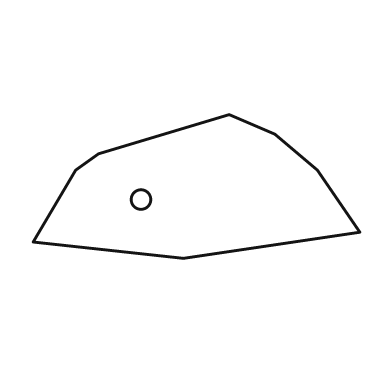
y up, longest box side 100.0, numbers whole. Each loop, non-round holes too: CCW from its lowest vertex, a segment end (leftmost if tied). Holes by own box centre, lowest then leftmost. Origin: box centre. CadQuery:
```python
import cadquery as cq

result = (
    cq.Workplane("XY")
    .moveTo(-4.0, -22.0)
    .lineTo(50.0, -14.0)
    .lineTo(37.0, 5.0)
    .lineTo(24.0, 16.0)
    .lineTo(10.0, 22.0)
    .lineTo(-30.0, 10.0)
    .lineTo(-37.0, 5.0)
    .lineTo(-50.0, -17.0)
    .close()
    .moveTo(-17.0, -4.0)
    .circle(3.0)
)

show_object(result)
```